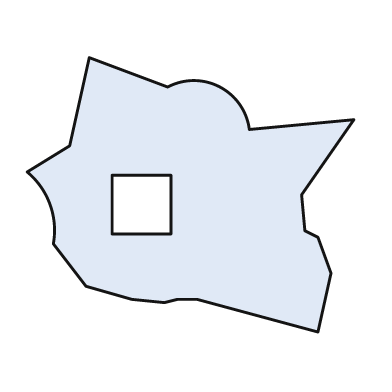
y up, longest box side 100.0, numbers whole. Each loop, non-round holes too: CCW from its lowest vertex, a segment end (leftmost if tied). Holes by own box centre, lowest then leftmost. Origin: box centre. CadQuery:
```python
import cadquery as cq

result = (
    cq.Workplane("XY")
    .moveTo(39.0, -42.0)
    .lineTo(43.0, -24.0)
    .lineTo(39.0, -13.0)
    .lineTo(35.0, -11.0)
    .lineTo(34.0, 0.0)
    .lineTo(50.0, 23.0)
    .lineTo(18.0, 20.0)
    .threePointArc((9.0, 33.0), (-7.0, 33.0))
    .lineTo(-31.0, 42.0)
    .lineTo(-37.0, 15.0)
    .lineTo(-50.0, 7.0)
    .threePointArc((-43.0, -3.0), (-42.0, -15.0))
    .lineTo(-32.0, -28.0)
    .lineTo(-18.0, -32.0)
    .lineTo(-8.0, -33.0)
    .lineTo(-4.0, -32.0)
    .lineTo(2.0, -32.0)
    .close()
    .moveTo(-24.0, -12.0)
    .lineTo(-6.0, -12.0)
    .lineTo(-6.0, 6.0)
    .lineTo(-24.0, 6.0)
    .close()
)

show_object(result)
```